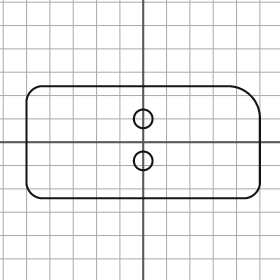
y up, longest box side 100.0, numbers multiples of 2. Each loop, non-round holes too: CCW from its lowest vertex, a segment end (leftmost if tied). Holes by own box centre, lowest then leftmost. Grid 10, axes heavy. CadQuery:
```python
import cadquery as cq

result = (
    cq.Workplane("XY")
    .moveTo(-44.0, -24.0)
    .lineTo(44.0, -24.0)
    .threePointArc((48.0, -22.0), (50.0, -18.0))
    .lineTo(50.0, 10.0)
    .threePointArc((46.0, 20.0), (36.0, 24.0))
    .lineTo(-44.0, 24.0)
    .threePointArc((-48.0, 22.0), (-50.0, 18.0))
    .lineTo(-50.0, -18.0)
    .threePointArc((-48.0, -22.0), (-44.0, -24.0))
    .close()
    .moveTo(0.0, -8.0)
    .circle(4.0)
    .moveTo(0.0, 10.0)
    .circle(4.0)
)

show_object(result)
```